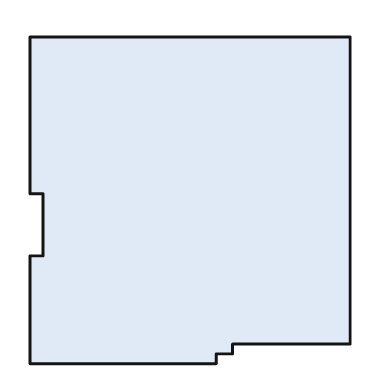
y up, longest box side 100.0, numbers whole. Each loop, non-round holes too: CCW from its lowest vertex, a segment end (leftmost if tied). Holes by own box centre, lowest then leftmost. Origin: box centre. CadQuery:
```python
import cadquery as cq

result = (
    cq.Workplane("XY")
    .moveTo(-49.0, -50.0)
    .lineTo(8.0, -50.0)
    .lineTo(8.0, -47.0)
    .lineTo(13.0, -47.0)
    .lineTo(13.0, -44.0)
    .lineTo(49.0, -44.0)
    .lineTo(49.0, 50.0)
    .lineTo(-49.0, 50.0)
    .lineTo(-49.0, 2.0)
    .lineTo(-45.0, 2.0)
    .lineTo(-45.0, -17.0)
    .lineTo(-49.0, -17.0)
    .close()
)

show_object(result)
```